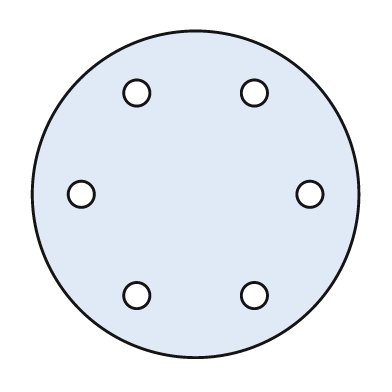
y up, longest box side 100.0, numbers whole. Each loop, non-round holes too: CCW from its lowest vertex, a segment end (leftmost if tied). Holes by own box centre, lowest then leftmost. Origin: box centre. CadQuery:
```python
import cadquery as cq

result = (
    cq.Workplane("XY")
    .moveTo(0.0, 0.0)
    .circle(50.0)
    .moveTo(-18.0, -31.0)
    .circle(4.0)
    .moveTo(18.0, -31.0)
    .circle(4.0)
    .moveTo(-35.0, 0.0)
    .circle(4.0)
    .moveTo(35.0, 0.0)
    .circle(4.0)
    .moveTo(-18.0, 31.0)
    .circle(4.0)
    .moveTo(18.0, 31.0)
    .circle(4.0)
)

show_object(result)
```